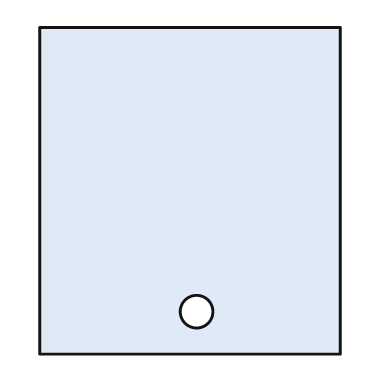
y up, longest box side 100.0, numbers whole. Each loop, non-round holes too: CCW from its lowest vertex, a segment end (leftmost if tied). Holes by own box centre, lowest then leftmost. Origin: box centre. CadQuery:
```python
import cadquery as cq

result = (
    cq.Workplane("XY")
    .moveTo(-46.0, -50.0)
    .lineTo(46.0, -50.0)
    .lineTo(46.0, 50.0)
    .lineTo(-46.0, 50.0)
    .close()
    .moveTo(2.0, -37.0)
    .circle(5.0)
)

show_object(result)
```